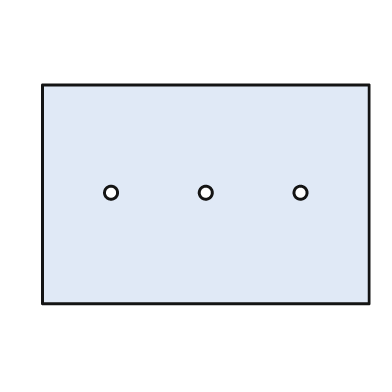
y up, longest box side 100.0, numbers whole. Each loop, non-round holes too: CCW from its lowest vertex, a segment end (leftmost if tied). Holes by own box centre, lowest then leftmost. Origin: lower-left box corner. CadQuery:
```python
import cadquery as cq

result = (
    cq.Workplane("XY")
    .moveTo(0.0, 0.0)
    .lineTo(100.0, 0.0)
    .lineTo(100.0, 67.0)
    .lineTo(0.0, 67.0)
    .close()
    .moveTo(21.0, 34.0)
    .circle(2.0)
    .moveTo(50.0, 34.0)
    .circle(2.0)
    .moveTo(79.0, 34.0)
    .circle(2.0)
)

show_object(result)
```